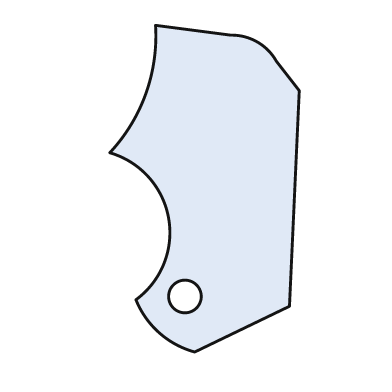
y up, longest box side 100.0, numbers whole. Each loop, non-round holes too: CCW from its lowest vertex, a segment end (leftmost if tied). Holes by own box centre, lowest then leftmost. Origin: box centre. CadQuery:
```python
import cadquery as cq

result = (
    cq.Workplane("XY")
    .moveTo(-3.0, -50.0)
    .lineTo(26.0, -36.0)
    .lineTo(29.0, 30.0)
    .lineTo(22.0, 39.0)
    .threePointArc((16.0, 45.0), (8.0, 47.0))
    .lineTo(-15.0, 50.0)
    .threePointArc((-18.0, 29.0), (-29.0, 11.0))
    .threePointArc((-11.0, -9.0), (-21.0, -34.0))
    .threePointArc((-14.0, -44.0), (-3.0, -50.0))
    .close()
    .moveTo(-6.0, -33.0)
    .circle(5.0)
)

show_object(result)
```